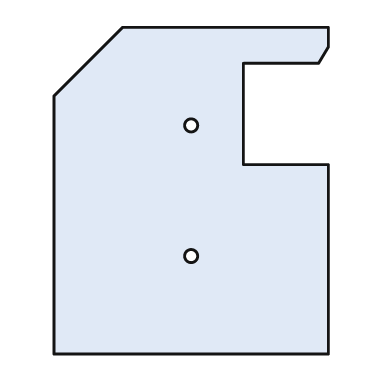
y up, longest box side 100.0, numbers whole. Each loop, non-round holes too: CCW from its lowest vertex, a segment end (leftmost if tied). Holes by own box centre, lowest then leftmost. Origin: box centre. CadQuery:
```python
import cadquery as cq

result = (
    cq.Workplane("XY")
    .moveTo(-42.0, -50.0)
    .lineTo(42.0, -50.0)
    .lineTo(42.0, 8.0)
    .lineTo(16.0, 8.0)
    .lineTo(16.0, 39.0)
    .lineTo(39.0, 39.0)
    .lineTo(42.0, 44.0)
    .lineTo(42.0, 50.0)
    .lineTo(-21.0, 50.0)
    .lineTo(-42.0, 29.0)
    .close()
    .moveTo(0.0, -20.0)
    .circle(2.0)
    .moveTo(0.0, 20.0)
    .circle(2.0)
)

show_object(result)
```